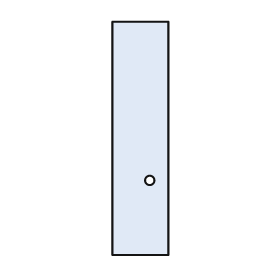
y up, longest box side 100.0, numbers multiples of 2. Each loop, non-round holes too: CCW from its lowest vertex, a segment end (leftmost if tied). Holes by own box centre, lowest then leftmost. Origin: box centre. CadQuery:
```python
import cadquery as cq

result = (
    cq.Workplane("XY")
    .moveTo(-12.0, -50.0)
    .lineTo(12.0, -50.0)
    .lineTo(12.0, 50.0)
    .lineTo(-12.0, 50.0)
    .close()
    .moveTo(4.0, -18.0)
    .circle(2.0)
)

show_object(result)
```